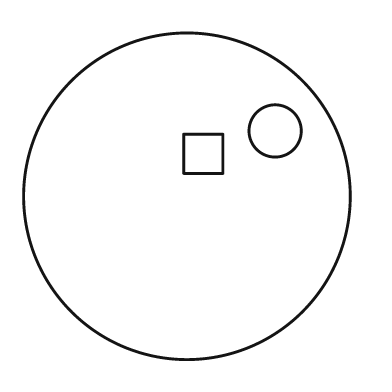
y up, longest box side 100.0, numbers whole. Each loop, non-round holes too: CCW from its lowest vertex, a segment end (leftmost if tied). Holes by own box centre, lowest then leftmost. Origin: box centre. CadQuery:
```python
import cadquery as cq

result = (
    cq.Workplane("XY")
    .moveTo(0.0, 0.0)
    .circle(50.0)
    .moveTo(-1.0, 7.0)
    .lineTo(11.0, 7.0)
    .lineTo(11.0, 19.0)
    .lineTo(-1.0, 19.0)
    .close()
    .moveTo(27.0, 20.0)
    .circle(8.0)
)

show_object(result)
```